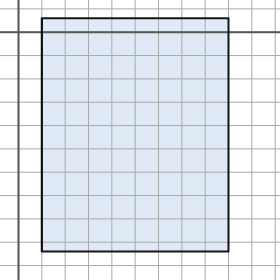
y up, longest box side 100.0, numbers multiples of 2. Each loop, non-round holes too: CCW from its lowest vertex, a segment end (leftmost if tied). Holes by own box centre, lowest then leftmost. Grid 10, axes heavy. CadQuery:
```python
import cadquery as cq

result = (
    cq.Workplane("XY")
    .moveTo(10.0, -94.0)
    .lineTo(90.0, -94.0)
    .lineTo(90.0, 6.0)
    .lineTo(10.0, 6.0)
    .close()
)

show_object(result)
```